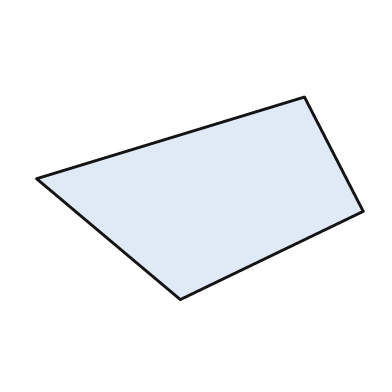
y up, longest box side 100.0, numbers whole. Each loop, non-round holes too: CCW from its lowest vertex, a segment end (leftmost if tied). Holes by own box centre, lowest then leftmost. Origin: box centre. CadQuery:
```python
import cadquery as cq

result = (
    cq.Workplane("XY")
    .moveTo(-6.0, -31.0)
    .lineTo(50.0, -4.0)
    .lineTo(32.0, 31.0)
    .lineTo(-50.0, 6.0)
    .close()
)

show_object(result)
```